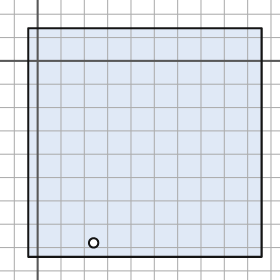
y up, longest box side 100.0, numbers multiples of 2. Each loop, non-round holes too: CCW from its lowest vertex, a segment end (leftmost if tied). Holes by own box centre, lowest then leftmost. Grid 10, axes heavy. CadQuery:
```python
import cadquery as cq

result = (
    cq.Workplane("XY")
    .moveTo(-4.0, -84.0)
    .lineTo(96.0, -84.0)
    .lineTo(96.0, 14.0)
    .lineTo(-4.0, 14.0)
    .close()
    .moveTo(24.0, -78.0)
    .circle(2.0)
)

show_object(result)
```